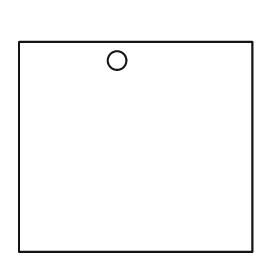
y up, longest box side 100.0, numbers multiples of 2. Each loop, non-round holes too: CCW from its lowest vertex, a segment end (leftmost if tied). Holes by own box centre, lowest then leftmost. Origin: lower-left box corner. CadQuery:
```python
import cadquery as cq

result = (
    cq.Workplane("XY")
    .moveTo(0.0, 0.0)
    .lineTo(100.0, 0.0)
    .lineTo(100.0, 90.0)
    .lineTo(0.0, 90.0)
    .close()
    .moveTo(42.0, 82.0)
    .circle(4.0)
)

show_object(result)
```